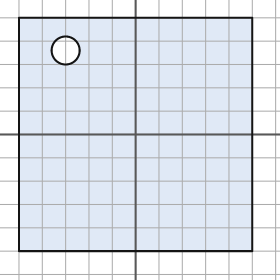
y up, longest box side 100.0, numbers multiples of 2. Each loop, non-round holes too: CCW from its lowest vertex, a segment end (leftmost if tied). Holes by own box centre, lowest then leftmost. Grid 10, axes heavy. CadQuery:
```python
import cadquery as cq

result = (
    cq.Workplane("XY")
    .moveTo(-50.0, -50.0)
    .lineTo(50.0, -50.0)
    .lineTo(50.0, 50.0)
    .lineTo(-50.0, 50.0)
    .close()
    .moveTo(-30.0, 36.0)
    .circle(6.0)
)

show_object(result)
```